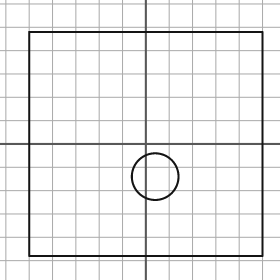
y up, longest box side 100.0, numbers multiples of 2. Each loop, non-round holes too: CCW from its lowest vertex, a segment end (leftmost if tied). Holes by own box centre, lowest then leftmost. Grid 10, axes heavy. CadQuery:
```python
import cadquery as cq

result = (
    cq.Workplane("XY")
    .moveTo(-50.0, -48.0)
    .lineTo(50.0, -48.0)
    .lineTo(50.0, 48.0)
    .lineTo(-50.0, 48.0)
    .close()
    .moveTo(4.0, -14.0)
    .circle(10.0)
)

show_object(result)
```